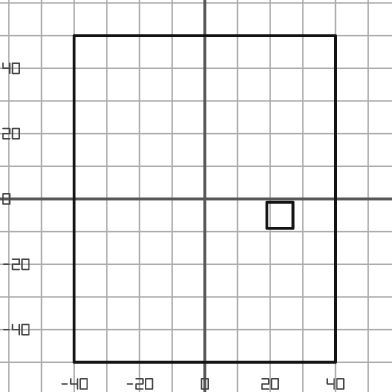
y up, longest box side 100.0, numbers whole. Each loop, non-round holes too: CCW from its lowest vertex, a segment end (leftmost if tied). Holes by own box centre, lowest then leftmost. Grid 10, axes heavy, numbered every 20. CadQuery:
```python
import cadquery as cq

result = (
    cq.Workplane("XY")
    .moveTo(-40.0, -50.0)
    .lineTo(40.0, -50.0)
    .lineTo(40.0, 50.0)
    .lineTo(-40.0, 50.0)
    .close()
    .moveTo(19.0, -9.0)
    .lineTo(27.0, -9.0)
    .lineTo(27.0, -1.0)
    .lineTo(19.0, -1.0)
    .close()
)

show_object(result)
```